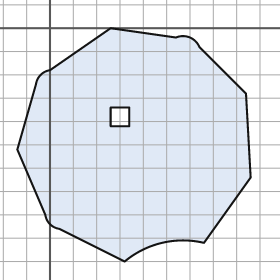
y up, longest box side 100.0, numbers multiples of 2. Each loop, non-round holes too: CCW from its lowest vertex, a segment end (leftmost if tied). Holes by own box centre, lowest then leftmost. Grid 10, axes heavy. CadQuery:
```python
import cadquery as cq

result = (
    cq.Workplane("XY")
    .moveTo(32.0, -100.0)
    .threePointArc((48.0, -92.0), (66.0, -92.0))
    .lineTo(86.0, -64.0)
    .lineTo(84.0, -28.0)
    .lineTo(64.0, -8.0)
    .threePointArc((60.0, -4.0), (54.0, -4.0))
    .lineTo(26.0, 0.0)
    .lineTo(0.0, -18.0)
    .threePointArc((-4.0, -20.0), (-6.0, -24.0))
    .lineTo(-14.0, -52.0)
    .lineTo(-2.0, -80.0)
    .threePointArc((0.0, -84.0), (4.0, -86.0))
    .close()
    .moveTo(26.0, -42.0)
    .lineTo(34.0, -42.0)
    .lineTo(34.0, -34.0)
    .lineTo(26.0, -34.0)
    .close()
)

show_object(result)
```